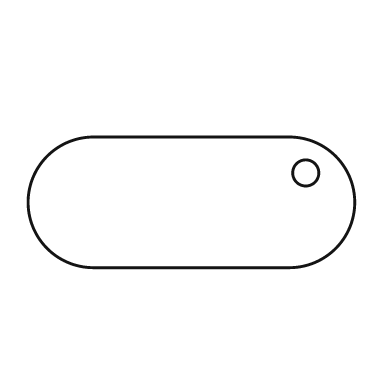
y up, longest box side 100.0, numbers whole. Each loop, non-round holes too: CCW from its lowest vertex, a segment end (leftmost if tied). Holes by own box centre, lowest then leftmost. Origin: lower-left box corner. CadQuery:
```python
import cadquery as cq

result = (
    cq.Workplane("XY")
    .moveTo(20.0, 0.0)
    .lineTo(80.0, 0.0)
    .threePointArc((100.0, 20.0), (80.0, 40.0))
    .lineTo(20.0, 40.0)
    .threePointArc((0.0, 20.0), (20.0, 0.0))
    .close()
    .moveTo(85.0, 29.0)
    .circle(4.0)
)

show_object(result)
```